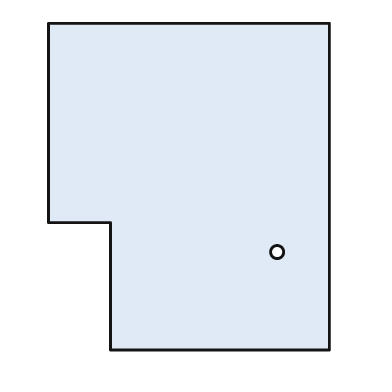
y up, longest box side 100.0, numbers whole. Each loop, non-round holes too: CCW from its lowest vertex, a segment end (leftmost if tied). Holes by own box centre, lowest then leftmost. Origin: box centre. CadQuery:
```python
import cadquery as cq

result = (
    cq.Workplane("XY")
    .moveTo(-24.0, -50.0)
    .lineTo(43.0, -50.0)
    .lineTo(43.0, 50.0)
    .lineTo(-43.0, 50.0)
    .lineTo(-43.0, -11.0)
    .lineTo(-24.0, -11.0)
    .close()
    .moveTo(27.0, -20.0)
    .circle(2.0)
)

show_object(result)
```